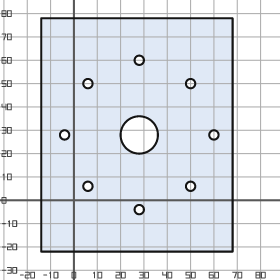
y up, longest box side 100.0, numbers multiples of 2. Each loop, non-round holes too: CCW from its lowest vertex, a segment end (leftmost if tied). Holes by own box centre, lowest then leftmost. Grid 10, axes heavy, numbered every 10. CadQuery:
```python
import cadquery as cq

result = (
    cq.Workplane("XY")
    .moveTo(-14.0, -22.0)
    .lineTo(68.0, -22.0)
    .lineTo(68.0, 78.0)
    .lineTo(-14.0, 78.0)
    .close()
    .moveTo(28.0, -4.0)
    .circle(2.0)
    .moveTo(6.0, 6.0)
    .circle(2.0)
    .moveTo(50.0, 6.0)
    .circle(2.0)
    .moveTo(-4.0, 28.0)
    .circle(2.0)
    .moveTo(28.0, 28.0)
    .circle(8.0)
    .moveTo(60.0, 28.0)
    .circle(2.0)
    .moveTo(6.0, 50.0)
    .circle(2.0)
    .moveTo(50.0, 50.0)
    .circle(2.0)
    .moveTo(28.0, 60.0)
    .circle(2.0)
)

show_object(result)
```